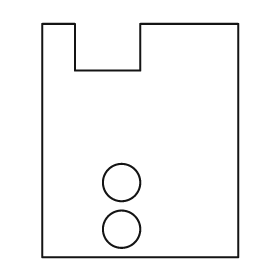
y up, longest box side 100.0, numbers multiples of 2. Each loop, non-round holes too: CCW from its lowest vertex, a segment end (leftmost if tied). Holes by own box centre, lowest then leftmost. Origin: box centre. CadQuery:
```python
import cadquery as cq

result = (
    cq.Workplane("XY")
    .moveTo(-42.0, -50.0)
    .lineTo(42.0, -50.0)
    .lineTo(42.0, 50.0)
    .lineTo(0.0, 50.0)
    .lineTo(0.0, 30.0)
    .lineTo(-28.0, 30.0)
    .lineTo(-28.0, 50.0)
    .lineTo(-42.0, 50.0)
    .close()
    .moveTo(-8.0, -38.0)
    .circle(8.0)
    .moveTo(-8.0, -18.0)
    .circle(8.0)
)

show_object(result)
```